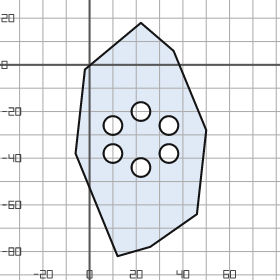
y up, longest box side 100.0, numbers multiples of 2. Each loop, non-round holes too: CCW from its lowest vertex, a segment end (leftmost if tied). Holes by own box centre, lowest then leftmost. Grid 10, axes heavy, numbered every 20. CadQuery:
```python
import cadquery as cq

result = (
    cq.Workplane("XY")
    .moveTo(12.0, -82.0)
    .lineTo(26.0, -78.0)
    .lineTo(46.0, -64.0)
    .lineTo(50.0, -28.0)
    .lineTo(36.0, 6.0)
    .lineTo(22.0, 18.0)
    .lineTo(-2.0, -2.0)
    .lineTo(-6.0, -38.0)
    .close()
    .moveTo(22.0, -44.0)
    .circle(4.0)
    .moveTo(10.0, -38.0)
    .circle(4.0)
    .moveTo(34.0, -38.0)
    .circle(4.0)
    .moveTo(10.0, -26.0)
    .circle(4.0)
    .moveTo(34.0, -26.0)
    .circle(4.0)
    .moveTo(22.0, -20.0)
    .circle(4.0)
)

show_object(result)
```